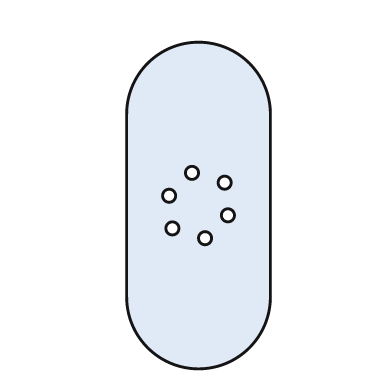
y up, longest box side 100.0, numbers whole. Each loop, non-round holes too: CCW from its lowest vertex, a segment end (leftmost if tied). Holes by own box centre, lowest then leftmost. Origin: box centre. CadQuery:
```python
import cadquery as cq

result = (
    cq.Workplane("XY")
    .moveTo(-22.0, -28.0)
    .threePointArc((0.0, -50.0), (22.0, -28.0))
    .lineTo(22.0, 28.0)
    .threePointArc((0.0, 50.0), (-22.0, 28.0))
    .close()
    .moveTo(2.0, -10.0)
    .circle(2.0)
    .moveTo(-8.0, -7.0)
    .circle(2.0)
    .moveTo(9.0, -3.0)
    .circle(2.0)
    .moveTo(-9.0, 3.0)
    .circle(2.0)
    .moveTo(8.0, 7.0)
    .circle(2.0)
    .moveTo(-2.0, 10.0)
    .circle(2.0)
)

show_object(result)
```